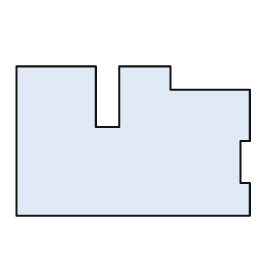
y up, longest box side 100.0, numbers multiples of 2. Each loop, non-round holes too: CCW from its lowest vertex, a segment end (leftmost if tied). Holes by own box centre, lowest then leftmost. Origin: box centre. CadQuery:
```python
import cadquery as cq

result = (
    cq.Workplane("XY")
    .moveTo(-50.0, -32.0)
    .lineTo(50.0, -32.0)
    .lineTo(50.0, -18.0)
    .lineTo(46.0, -18.0)
    .lineTo(46.0, 0.0)
    .lineTo(50.0, 0.0)
    .lineTo(50.0, 22.0)
    .lineTo(16.0, 22.0)
    .lineTo(16.0, 32.0)
    .lineTo(-6.0, 32.0)
    .lineTo(-6.0, 6.0)
    .lineTo(-16.0, 6.0)
    .lineTo(-16.0, 32.0)
    .lineTo(-50.0, 32.0)
    .close()
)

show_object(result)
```